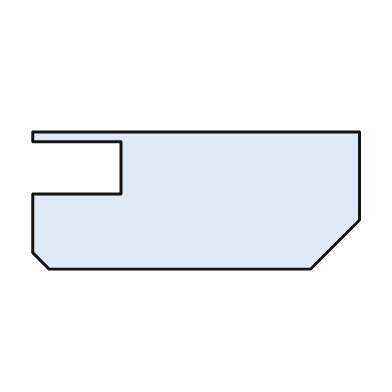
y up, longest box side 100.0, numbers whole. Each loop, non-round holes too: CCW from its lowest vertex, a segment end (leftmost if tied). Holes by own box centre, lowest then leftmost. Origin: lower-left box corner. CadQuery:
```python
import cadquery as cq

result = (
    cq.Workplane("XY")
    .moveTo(5.0, 0.0)
    .lineTo(85.0, 0.0)
    .lineTo(100.0, 15.0)
    .lineTo(100.0, 42.0)
    .lineTo(0.0, 42.0)
    .lineTo(0.0, 39.0)
    .lineTo(27.0, 39.0)
    .lineTo(27.0, 23.0)
    .lineTo(0.0, 23.0)
    .lineTo(0.0, 5.0)
    .close()
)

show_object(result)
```